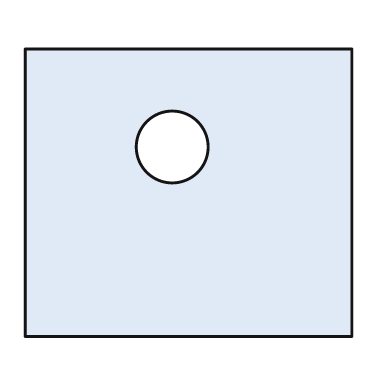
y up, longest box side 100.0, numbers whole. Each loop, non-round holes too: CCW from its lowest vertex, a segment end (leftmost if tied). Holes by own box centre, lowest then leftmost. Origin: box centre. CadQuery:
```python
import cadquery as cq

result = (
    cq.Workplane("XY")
    .moveTo(-50.0, -44.0)
    .lineTo(50.0, -44.0)
    .lineTo(50.0, 44.0)
    .lineTo(-50.0, 44.0)
    .close()
    .moveTo(-5.0, 14.0)
    .circle(11.0)
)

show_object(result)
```